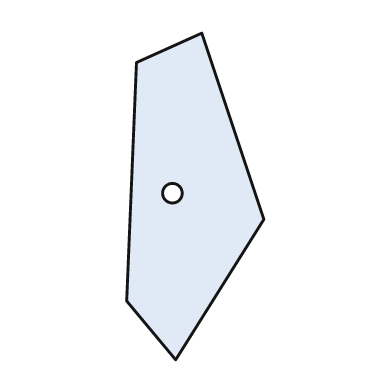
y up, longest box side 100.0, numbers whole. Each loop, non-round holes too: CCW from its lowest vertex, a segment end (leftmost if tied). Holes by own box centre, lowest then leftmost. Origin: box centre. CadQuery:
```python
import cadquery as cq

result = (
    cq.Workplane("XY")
    .moveTo(-6.0, -50.0)
    .lineTo(21.0, -7.0)
    .lineTo(2.0, 50.0)
    .lineTo(-18.0, 41.0)
    .lineTo(-21.0, -32.0)
    .close()
    .moveTo(-7.0, 1.0)
    .circle(3.0)
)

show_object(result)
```